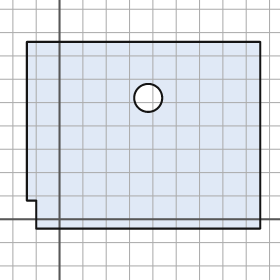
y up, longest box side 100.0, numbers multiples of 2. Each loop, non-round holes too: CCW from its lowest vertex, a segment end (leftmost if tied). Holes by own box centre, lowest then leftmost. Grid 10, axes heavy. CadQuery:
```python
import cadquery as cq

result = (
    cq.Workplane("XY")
    .moveTo(-10.0, -4.0)
    .lineTo(86.0, -4.0)
    .lineTo(86.0, 76.0)
    .lineTo(-14.0, 76.0)
    .lineTo(-14.0, 8.0)
    .lineTo(-10.0, 8.0)
    .close()
    .moveTo(38.0, 52.0)
    .circle(6.0)
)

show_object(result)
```